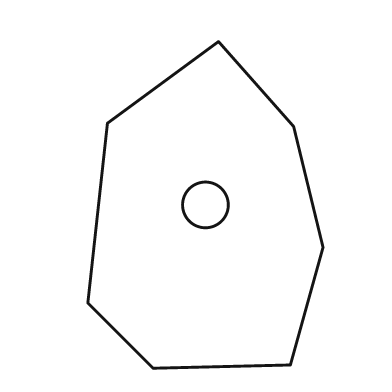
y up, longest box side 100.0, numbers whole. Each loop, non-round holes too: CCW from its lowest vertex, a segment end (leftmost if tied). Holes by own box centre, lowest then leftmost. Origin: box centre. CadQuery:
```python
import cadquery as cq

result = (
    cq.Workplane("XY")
    .moveTo(-16.0, -50.0)
    .lineTo(26.0, -49.0)
    .lineTo(36.0, -13.0)
    .lineTo(27.0, 24.0)
    .lineTo(4.0, 50.0)
    .lineTo(-30.0, 25.0)
    .lineTo(-36.0, -30.0)
    .close()
    .moveTo(0.0, 0.0)
    .circle(7.0)
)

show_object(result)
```